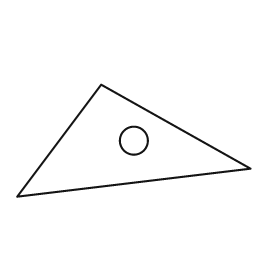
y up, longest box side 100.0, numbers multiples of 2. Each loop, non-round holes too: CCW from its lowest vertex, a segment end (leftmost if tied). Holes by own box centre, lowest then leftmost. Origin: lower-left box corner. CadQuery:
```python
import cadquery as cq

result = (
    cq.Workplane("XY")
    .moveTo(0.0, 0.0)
    .lineTo(100.0, 12.0)
    .lineTo(36.0, 48.0)
    .close()
    .moveTo(50.0, 24.0)
    .circle(6.0)
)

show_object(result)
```